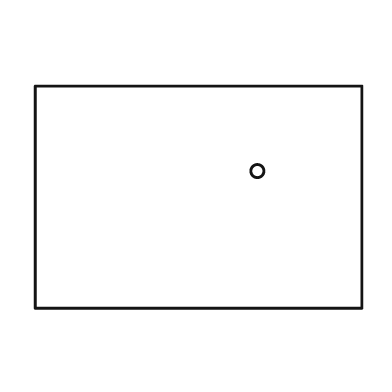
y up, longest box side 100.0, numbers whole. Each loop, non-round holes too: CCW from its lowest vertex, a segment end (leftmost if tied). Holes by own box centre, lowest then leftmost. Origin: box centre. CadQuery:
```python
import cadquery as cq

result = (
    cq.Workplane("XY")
    .moveTo(-50.0, -34.0)
    .lineTo(50.0, -34.0)
    .lineTo(50.0, 34.0)
    .lineTo(-50.0, 34.0)
    .close()
    .moveTo(18.0, 8.0)
    .circle(2.0)
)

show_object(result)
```